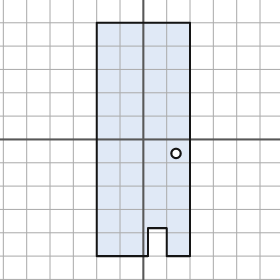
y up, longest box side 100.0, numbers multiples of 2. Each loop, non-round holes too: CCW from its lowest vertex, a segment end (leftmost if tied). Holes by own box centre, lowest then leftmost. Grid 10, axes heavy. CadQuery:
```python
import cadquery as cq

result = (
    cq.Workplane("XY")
    .moveTo(-20.0, -50.0)
    .lineTo(2.0, -50.0)
    .lineTo(2.0, -38.0)
    .lineTo(10.0, -38.0)
    .lineTo(10.0, -50.0)
    .lineTo(20.0, -50.0)
    .lineTo(20.0, 50.0)
    .lineTo(-20.0, 50.0)
    .close()
    .moveTo(14.0, -6.0)
    .circle(2.0)
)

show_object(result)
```